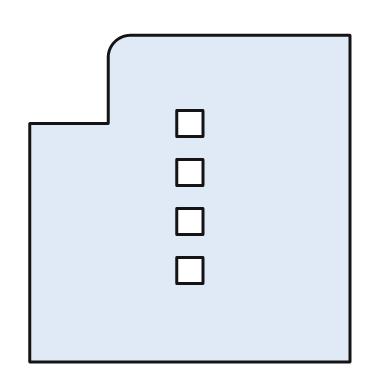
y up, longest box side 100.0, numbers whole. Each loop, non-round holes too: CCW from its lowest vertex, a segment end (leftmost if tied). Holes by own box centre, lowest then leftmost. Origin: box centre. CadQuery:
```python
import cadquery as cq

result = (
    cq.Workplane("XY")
    .moveTo(-49.0, -50.0)
    .lineTo(49.0, -50.0)
    .lineTo(49.0, 50.0)
    .lineTo(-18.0, 50.0)
    .threePointArc((-23.0, 48.0), (-25.0, 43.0))
    .lineTo(-25.0, 23.0)
    .lineTo(-49.0, 23.0)
    .close()
    .moveTo(-4.0, -26.0)
    .lineTo(4.0, -26.0)
    .lineTo(4.0, -18.0)
    .lineTo(-4.0, -18.0)
    .close()
    .moveTo(-4.0, -11.0)
    .lineTo(4.0, -11.0)
    .lineTo(4.0, -3.0)
    .lineTo(-4.0, -3.0)
    .close()
    .moveTo(-4.0, 4.0)
    .lineTo(4.0, 4.0)
    .lineTo(4.0, 12.0)
    .lineTo(-4.0, 12.0)
    .close()
    .moveTo(-4.0, 19.0)
    .lineTo(4.0, 19.0)
    .lineTo(4.0, 27.0)
    .lineTo(-4.0, 27.0)
    .close()
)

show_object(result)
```